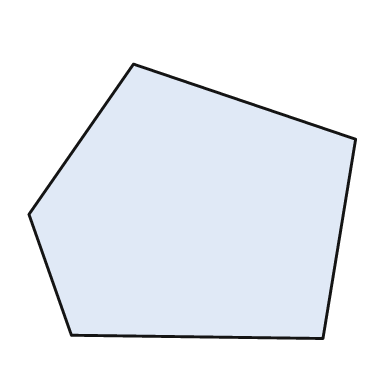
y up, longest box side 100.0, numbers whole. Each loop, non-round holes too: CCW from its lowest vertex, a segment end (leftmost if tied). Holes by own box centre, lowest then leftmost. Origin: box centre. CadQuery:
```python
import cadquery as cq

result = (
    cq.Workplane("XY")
    .moveTo(40.0, -42.0)
    .lineTo(50.0, 19.0)
    .lineTo(-18.0, 42.0)
    .lineTo(-50.0, -4.0)
    .lineTo(-37.0, -41.0)
    .close()
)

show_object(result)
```